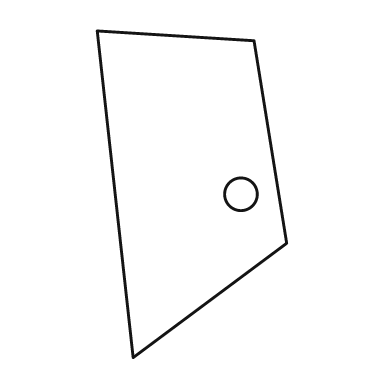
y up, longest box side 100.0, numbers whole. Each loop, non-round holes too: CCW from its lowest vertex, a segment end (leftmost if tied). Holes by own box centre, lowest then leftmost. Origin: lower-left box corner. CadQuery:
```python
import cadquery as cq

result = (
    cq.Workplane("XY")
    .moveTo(11.0, 0.0)
    .lineTo(58.0, 35.0)
    .lineTo(48.0, 97.0)
    .lineTo(0.0, 100.0)
    .close()
    .moveTo(44.0, 50.0)
    .circle(5.0)
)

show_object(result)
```